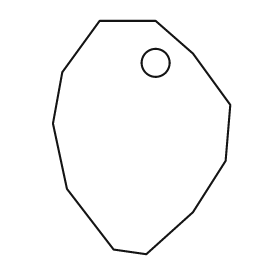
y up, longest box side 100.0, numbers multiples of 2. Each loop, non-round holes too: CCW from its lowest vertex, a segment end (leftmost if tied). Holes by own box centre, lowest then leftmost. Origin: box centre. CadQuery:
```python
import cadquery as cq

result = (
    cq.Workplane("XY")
    .moveTo(2.0, -50.0)
    .lineTo(22.0, -32.0)
    .lineTo(36.0, -10.0)
    .lineTo(38.0, 14.0)
    .lineTo(22.0, 36.0)
    .lineTo(6.0, 50.0)
    .lineTo(-18.0, 50.0)
    .lineTo(-34.0, 28.0)
    .lineTo(-38.0, 6.0)
    .lineTo(-32.0, -22.0)
    .lineTo(-12.0, -48.0)
    .close()
    .moveTo(6.0, 32.0)
    .circle(6.0)
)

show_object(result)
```